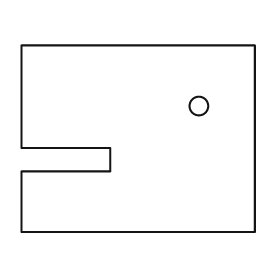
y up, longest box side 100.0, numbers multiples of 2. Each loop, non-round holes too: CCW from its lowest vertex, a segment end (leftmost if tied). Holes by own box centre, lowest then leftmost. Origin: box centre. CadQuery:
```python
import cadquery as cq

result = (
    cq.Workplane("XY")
    .moveTo(-50.0, -40.0)
    .lineTo(50.0, -40.0)
    .lineTo(50.0, 40.0)
    .lineTo(-50.0, 40.0)
    .lineTo(-50.0, -4.0)
    .lineTo(-12.0, -4.0)
    .lineTo(-12.0, -14.0)
    .lineTo(-50.0, -14.0)
    .close()
    .moveTo(26.0, 14.0)
    .circle(4.0)
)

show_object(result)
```